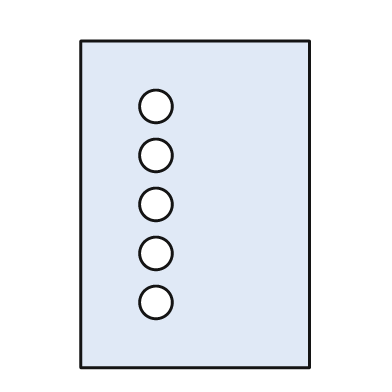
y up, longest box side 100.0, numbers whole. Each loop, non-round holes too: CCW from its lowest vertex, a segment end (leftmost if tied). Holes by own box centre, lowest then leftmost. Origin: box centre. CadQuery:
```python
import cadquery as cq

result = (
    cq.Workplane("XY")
    .moveTo(-35.0, -50.0)
    .lineTo(35.0, -50.0)
    .lineTo(35.0, 50.0)
    .lineTo(-35.0, 50.0)
    .close()
    .moveTo(-12.0, -30.0)
    .circle(5.0)
    .moveTo(-12.0, -15.0)
    .circle(5.0)
    .moveTo(-12.0, 0.0)
    .circle(5.0)
    .moveTo(-12.0, 15.0)
    .circle(5.0)
    .moveTo(-12.0, 30.0)
    .circle(5.0)
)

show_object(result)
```